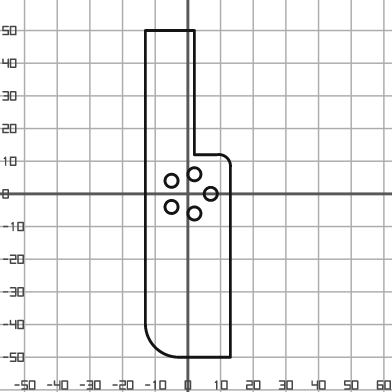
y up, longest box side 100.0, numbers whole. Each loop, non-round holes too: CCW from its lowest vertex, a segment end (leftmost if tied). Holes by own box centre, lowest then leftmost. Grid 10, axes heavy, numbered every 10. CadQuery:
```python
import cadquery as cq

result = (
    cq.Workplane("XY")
    .moveTo(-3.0, -50.0)
    .lineTo(13.0, -50.0)
    .lineTo(13.0, 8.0)
    .threePointArc((12.0, 11.0), (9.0, 12.0))
    .lineTo(2.0, 12.0)
    .lineTo(2.0, 50.0)
    .lineTo(-13.0, 50.0)
    .lineTo(-13.0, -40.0)
    .threePointArc((-10.0, -47.0), (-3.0, -50.0))
    .close()
    .moveTo(2.0, -6.0)
    .circle(2.0)
    .moveTo(-5.0, -4.0)
    .circle(2.0)
    .moveTo(7.0, 0.0)
    .circle(2.0)
    .moveTo(-5.0, 4.0)
    .circle(2.0)
    .moveTo(2.0, 6.0)
    .circle(2.0)
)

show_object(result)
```